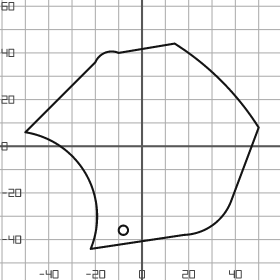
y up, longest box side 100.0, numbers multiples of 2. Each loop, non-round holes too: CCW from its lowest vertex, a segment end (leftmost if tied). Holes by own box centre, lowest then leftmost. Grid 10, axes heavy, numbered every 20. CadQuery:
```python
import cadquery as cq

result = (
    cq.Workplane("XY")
    .moveTo(-22.0, -44.0)
    .lineTo(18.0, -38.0)
    .threePointArc((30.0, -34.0), (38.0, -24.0))
    .lineTo(50.0, 8.0)
    .threePointArc((34.0, 28.0), (14.0, 44.0))
    .lineTo(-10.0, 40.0)
    .threePointArc((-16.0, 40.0), (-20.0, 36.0))
    .lineTo(-50.0, 6.0)
    .threePointArc((-24.0, -12.0), (-22.0, -44.0))
    .close()
    .moveTo(-8.0, -36.0)
    .circle(2.0)
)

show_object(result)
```